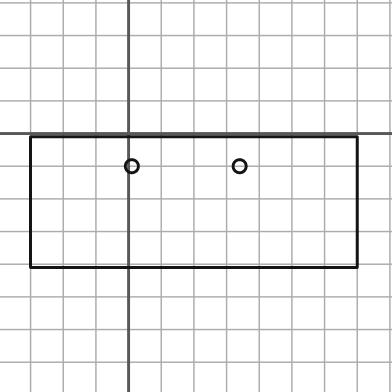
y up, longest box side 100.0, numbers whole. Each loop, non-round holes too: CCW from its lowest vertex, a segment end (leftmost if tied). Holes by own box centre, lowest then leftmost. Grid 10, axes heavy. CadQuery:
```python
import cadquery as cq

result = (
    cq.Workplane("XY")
    .moveTo(-30.0, -41.0)
    .lineTo(70.0, -41.0)
    .lineTo(70.0, -1.0)
    .lineTo(-30.0, -1.0)
    .close()
    .moveTo(1.0, -10.0)
    .circle(2.0)
    .moveTo(34.0, -10.0)
    .circle(2.0)
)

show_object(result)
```